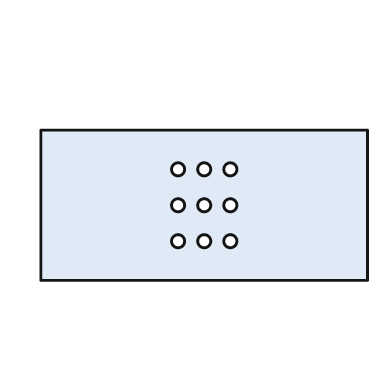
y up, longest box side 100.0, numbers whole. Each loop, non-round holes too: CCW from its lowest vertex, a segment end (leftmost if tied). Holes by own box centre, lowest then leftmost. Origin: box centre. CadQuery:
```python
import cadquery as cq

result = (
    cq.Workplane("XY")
    .moveTo(-50.0, -23.0)
    .lineTo(50.0, -23.0)
    .lineTo(50.0, 23.0)
    .lineTo(-50.0, 23.0)
    .close()
    .moveTo(-8.0, -11.0)
    .circle(2.0)
    .moveTo(0.0, -11.0)
    .circle(2.0)
    .moveTo(8.0, -11.0)
    .circle(2.0)
    .moveTo(-8.0, 0.0)
    .circle(2.0)
    .moveTo(0.0, 0.0)
    .circle(2.0)
    .moveTo(8.0, 0.0)
    .circle(2.0)
    .moveTo(-8.0, 11.0)
    .circle(2.0)
    .moveTo(0.0, 11.0)
    .circle(2.0)
    .moveTo(8.0, 11.0)
    .circle(2.0)
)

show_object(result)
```